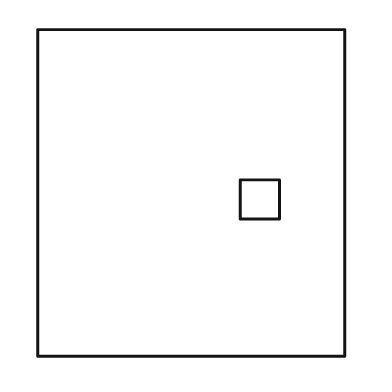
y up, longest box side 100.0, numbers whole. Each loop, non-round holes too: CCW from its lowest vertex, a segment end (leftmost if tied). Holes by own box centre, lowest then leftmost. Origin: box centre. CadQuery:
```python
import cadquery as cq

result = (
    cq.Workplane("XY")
    .moveTo(-47.0, -50.0)
    .lineTo(47.0, -50.0)
    .lineTo(47.0, 50.0)
    .lineTo(-47.0, 50.0)
    .close()
    .moveTo(15.0, -8.0)
    .lineTo(27.0, -8.0)
    .lineTo(27.0, 4.0)
    .lineTo(15.0, 4.0)
    .close()
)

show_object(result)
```